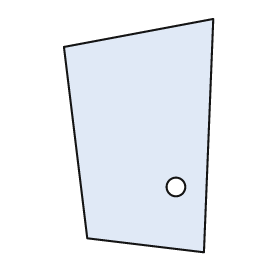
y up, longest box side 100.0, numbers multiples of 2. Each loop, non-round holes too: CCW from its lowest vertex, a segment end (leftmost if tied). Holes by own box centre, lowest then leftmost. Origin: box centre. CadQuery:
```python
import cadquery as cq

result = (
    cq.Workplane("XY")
    .moveTo(28.0, -50.0)
    .lineTo(32.0, 50.0)
    .lineTo(-32.0, 38.0)
    .lineTo(-22.0, -44.0)
    .close()
    .moveTo(16.0, -22.0)
    .circle(4.0)
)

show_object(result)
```